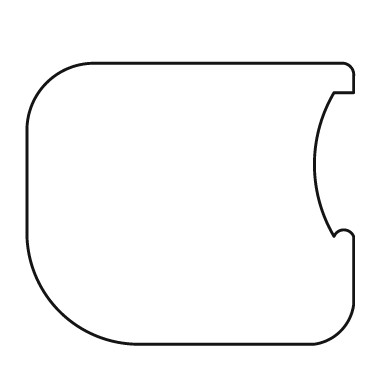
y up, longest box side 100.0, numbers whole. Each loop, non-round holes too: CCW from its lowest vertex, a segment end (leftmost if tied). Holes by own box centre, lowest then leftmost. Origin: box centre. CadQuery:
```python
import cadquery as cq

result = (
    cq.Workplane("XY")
    .moveTo(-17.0, -43.0)
    .lineTo(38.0, -43.0)
    .threePointArc((46.0, -39.0), (50.0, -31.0))
    .lineTo(50.0, -10.0)
    .threePointArc((47.0, -8.0), (44.0, -10.0))
    .threePointArc((38.0, 12.0), (44.0, 34.0))
    .lineTo(50.0, 34.0)
    .lineTo(50.0, 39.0)
    .threePointArc((49.0, 42.0), (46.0, 43.0))
    .lineTo(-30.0, 43.0)
    .threePointArc((-44.0, 37.0), (-50.0, 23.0))
    .lineTo(-50.0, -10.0)
    .threePointArc((-40.0, -33.0), (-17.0, -43.0))
    .close()
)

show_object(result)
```